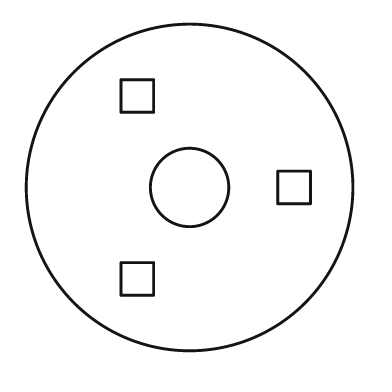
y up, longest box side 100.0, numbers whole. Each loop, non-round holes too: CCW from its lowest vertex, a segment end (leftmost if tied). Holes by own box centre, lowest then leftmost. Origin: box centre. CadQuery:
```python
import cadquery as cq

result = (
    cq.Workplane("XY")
    .moveTo(0.0, 0.0)
    .circle(50.0)
    .moveTo(-21.0, -33.0)
    .lineTo(-11.0, -33.0)
    .lineTo(-11.0, -23.0)
    .lineTo(-21.0, -23.0)
    .close()
    .moveTo(0.0, 0.0)
    .circle(12.0)
    .moveTo(27.0, -5.0)
    .lineTo(37.0, -5.0)
    .lineTo(37.0, 5.0)
    .lineTo(27.0, 5.0)
    .close()
    .moveTo(-21.0, 23.0)
    .lineTo(-11.0, 23.0)
    .lineTo(-11.0, 33.0)
    .lineTo(-21.0, 33.0)
    .close()
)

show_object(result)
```